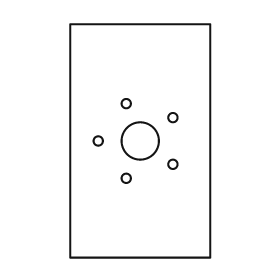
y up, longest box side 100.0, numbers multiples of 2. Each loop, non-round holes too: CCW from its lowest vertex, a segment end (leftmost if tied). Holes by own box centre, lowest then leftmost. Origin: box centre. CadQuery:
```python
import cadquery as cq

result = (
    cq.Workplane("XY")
    .moveTo(-30.0, -50.0)
    .lineTo(30.0, -50.0)
    .lineTo(30.0, 50.0)
    .lineTo(-30.0, 50.0)
    .close()
    .moveTo(-6.0, -16.0)
    .circle(2.0)
    .moveTo(14.0, -10.0)
    .circle(2.0)
    .moveTo(-18.0, 0.0)
    .circle(2.0)
    .moveTo(0.0, 0.0)
    .circle(8.0)
    .moveTo(14.0, 10.0)
    .circle(2.0)
    .moveTo(-6.0, 16.0)
    .circle(2.0)
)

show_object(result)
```